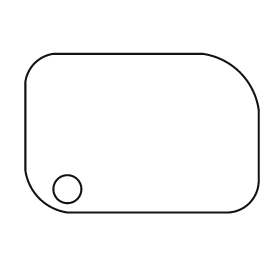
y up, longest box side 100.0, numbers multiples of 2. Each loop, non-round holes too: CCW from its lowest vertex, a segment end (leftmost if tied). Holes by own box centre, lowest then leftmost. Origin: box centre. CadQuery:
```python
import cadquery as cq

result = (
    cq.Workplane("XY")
    .moveTo(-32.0, -34.0)
    .lineTo(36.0, -34.0)
    .threePointArc((46.0, -30.0), (50.0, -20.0))
    .lineTo(50.0, 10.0)
    .threePointArc((42.0, 26.0), (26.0, 34.0))
    .lineTo(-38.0, 34.0)
    .threePointArc((-46.0, 30.0), (-50.0, 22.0))
    .lineTo(-50.0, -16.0)
    .threePointArc((-44.0, -28.0), (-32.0, -34.0))
    .close()
    .moveTo(-32.0, -24.0)
    .circle(6.0)
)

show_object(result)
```